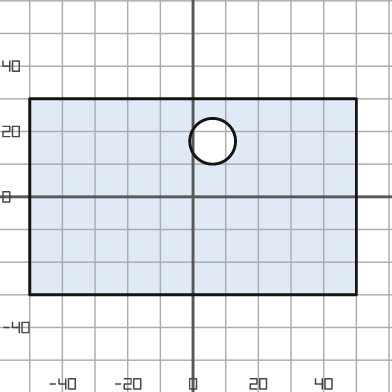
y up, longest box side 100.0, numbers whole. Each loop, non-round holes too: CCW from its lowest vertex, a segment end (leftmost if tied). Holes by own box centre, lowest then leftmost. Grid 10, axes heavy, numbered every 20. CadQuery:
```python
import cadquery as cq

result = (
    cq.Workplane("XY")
    .moveTo(-50.0, -30.0)
    .lineTo(50.0, -30.0)
    .lineTo(50.0, 30.0)
    .lineTo(-50.0, 30.0)
    .close()
    .moveTo(6.0, 17.0)
    .circle(7.0)
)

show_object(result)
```